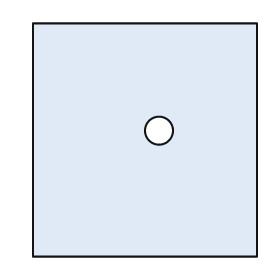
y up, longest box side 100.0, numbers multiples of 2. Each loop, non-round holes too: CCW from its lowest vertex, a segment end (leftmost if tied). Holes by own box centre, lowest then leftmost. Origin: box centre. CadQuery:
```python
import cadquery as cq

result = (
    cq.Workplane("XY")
    .moveTo(-48.0, -50.0)
    .lineTo(48.0, -50.0)
    .lineTo(48.0, 50.0)
    .lineTo(-48.0, 50.0)
    .close()
    .moveTo(6.0, 4.0)
    .circle(6.0)
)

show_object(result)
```